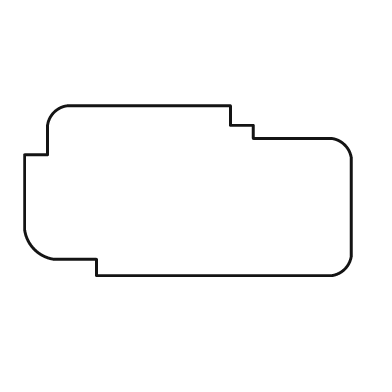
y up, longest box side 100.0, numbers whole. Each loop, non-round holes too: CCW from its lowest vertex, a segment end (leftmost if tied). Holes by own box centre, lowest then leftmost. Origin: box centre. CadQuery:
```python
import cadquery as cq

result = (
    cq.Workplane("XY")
    .moveTo(-28.0, -26.0)
    .lineTo(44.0, -26.0)
    .threePointArc((48.0, -24.0), (50.0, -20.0))
    .lineTo(50.0, 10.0)
    .threePointArc((48.0, 14.0), (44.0, 16.0))
    .lineTo(20.0, 16.0)
    .lineTo(20.0, 20.0)
    .lineTo(13.0, 20.0)
    .lineTo(13.0, 26.0)
    .lineTo(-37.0, 26.0)
    .threePointArc((-41.0, 24.0), (-43.0, 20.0))
    .lineTo(-43.0, 11.0)
    .lineTo(-50.0, 11.0)
    .lineTo(-50.0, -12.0)
    .threePointArc((-47.0, -18.0), (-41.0, -21.0))
    .lineTo(-28.0, -21.0)
    .close()
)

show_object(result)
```